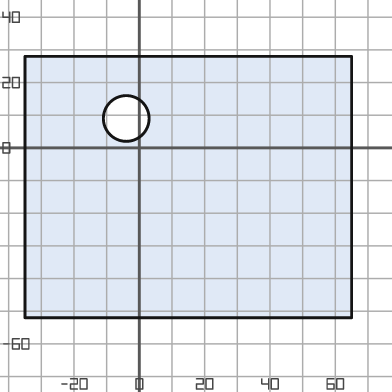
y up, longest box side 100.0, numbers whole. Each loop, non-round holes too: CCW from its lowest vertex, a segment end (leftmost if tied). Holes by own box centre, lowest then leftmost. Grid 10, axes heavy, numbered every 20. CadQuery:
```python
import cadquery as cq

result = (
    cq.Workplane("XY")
    .moveTo(-35.0, -52.0)
    .lineTo(65.0, -52.0)
    .lineTo(65.0, 28.0)
    .lineTo(-35.0, 28.0)
    .close()
    .moveTo(-4.0, 9.0)
    .circle(7.0)
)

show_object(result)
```